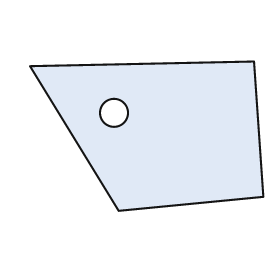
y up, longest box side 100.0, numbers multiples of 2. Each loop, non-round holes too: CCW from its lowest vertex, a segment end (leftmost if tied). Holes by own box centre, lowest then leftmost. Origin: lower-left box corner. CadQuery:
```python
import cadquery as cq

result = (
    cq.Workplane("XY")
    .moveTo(38.0, 0.0)
    .lineTo(100.0, 6.0)
    .lineTo(96.0, 64.0)
    .lineTo(0.0, 62.0)
    .close()
    .moveTo(36.0, 42.0)
    .circle(6.0)
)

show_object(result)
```